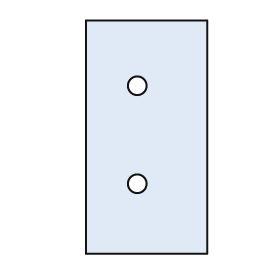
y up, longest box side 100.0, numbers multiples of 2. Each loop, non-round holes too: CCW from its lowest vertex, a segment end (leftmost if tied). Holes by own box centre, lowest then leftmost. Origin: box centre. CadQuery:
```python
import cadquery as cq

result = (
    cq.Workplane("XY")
    .moveTo(-26.0, -50.0)
    .lineTo(26.0, -50.0)
    .lineTo(26.0, 50.0)
    .lineTo(-26.0, 50.0)
    .close()
    .moveTo(-4.0, -20.0)
    .circle(4.0)
    .moveTo(-4.0, 22.0)
    .circle(4.0)
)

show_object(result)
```